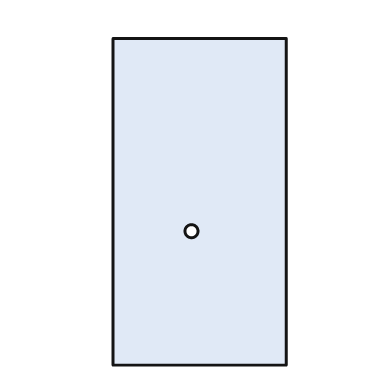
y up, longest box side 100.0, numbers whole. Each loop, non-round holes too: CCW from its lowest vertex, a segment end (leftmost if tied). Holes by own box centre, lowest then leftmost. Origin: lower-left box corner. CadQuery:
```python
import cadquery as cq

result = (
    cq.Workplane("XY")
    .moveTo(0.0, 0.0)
    .lineTo(53.0, 0.0)
    .lineTo(53.0, 100.0)
    .lineTo(0.0, 100.0)
    .close()
    .moveTo(24.0, 41.0)
    .circle(2.0)
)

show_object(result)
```